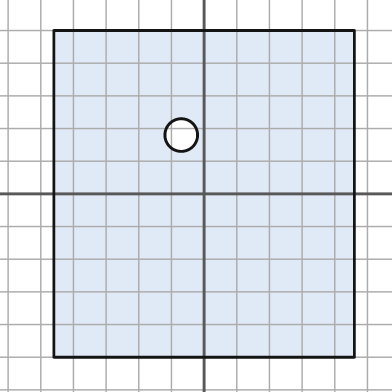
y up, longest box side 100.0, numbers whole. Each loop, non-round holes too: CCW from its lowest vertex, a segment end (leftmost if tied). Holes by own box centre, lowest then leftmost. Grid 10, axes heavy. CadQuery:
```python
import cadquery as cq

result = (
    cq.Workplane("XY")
    .moveTo(-46.0, -50.0)
    .lineTo(46.0, -50.0)
    .lineTo(46.0, 50.0)
    .lineTo(-46.0, 50.0)
    .close()
    .moveTo(-7.0, 18.0)
    .circle(5.0)
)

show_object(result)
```